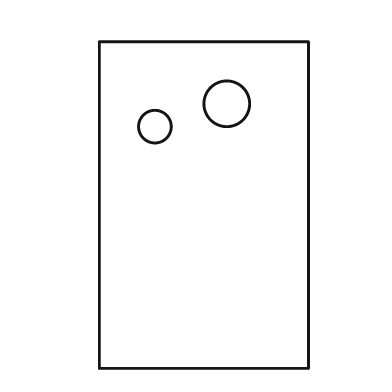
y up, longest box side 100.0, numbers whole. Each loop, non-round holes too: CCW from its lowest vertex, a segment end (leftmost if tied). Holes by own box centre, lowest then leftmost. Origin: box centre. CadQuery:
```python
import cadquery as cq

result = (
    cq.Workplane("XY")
    .moveTo(-32.0, -50.0)
    .lineTo(32.0, -50.0)
    .lineTo(32.0, 50.0)
    .lineTo(-32.0, 50.0)
    .close()
    .moveTo(-15.0, 24.0)
    .circle(5.0)
    .moveTo(7.0, 31.0)
    .circle(7.0)
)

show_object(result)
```